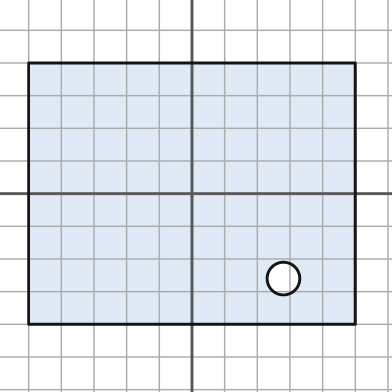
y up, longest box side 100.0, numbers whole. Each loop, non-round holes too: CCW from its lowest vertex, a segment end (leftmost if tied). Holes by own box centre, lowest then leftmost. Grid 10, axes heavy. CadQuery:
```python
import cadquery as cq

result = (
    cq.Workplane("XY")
    .moveTo(-50.0, -40.0)
    .lineTo(50.0, -40.0)
    .lineTo(50.0, 40.0)
    .lineTo(-50.0, 40.0)
    .close()
    .moveTo(28.0, -26.0)
    .circle(5.0)
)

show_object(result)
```